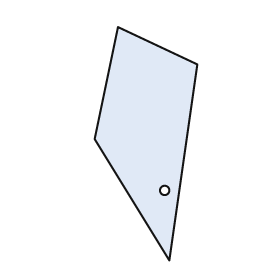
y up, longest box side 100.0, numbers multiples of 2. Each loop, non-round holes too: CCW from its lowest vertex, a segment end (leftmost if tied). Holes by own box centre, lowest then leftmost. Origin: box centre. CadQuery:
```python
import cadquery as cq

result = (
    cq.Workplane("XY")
    .moveTo(10.0, -50.0)
    .lineTo(22.0, 34.0)
    .lineTo(-12.0, 50.0)
    .lineTo(-22.0, 2.0)
    .close()
    .moveTo(8.0, -20.0)
    .circle(2.0)
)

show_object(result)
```